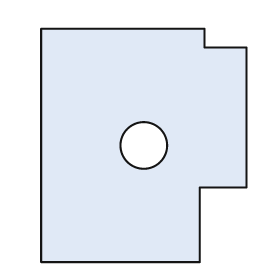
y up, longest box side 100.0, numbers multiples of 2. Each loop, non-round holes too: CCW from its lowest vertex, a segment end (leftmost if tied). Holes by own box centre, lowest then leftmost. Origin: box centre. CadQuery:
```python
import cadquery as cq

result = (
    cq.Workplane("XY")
    .moveTo(-44.0, -50.0)
    .lineTo(24.0, -50.0)
    .lineTo(24.0, -18.0)
    .lineTo(44.0, -18.0)
    .lineTo(44.0, 42.0)
    .lineTo(26.0, 42.0)
    .lineTo(26.0, 50.0)
    .lineTo(-44.0, 50.0)
    .close()
    .moveTo(0.0, 0.0)
    .circle(10.0)
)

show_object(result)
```